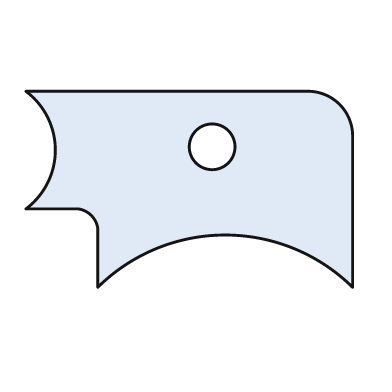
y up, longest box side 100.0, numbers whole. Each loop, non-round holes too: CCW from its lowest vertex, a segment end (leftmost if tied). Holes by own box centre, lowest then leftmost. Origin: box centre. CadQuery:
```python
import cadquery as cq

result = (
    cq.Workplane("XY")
    .moveTo(-28.0, -30.0)
    .threePointArc((11.0, -14.0), (50.0, -30.0))
    .lineTo(50.0, 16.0)
    .threePointArc((46.0, 26.0), (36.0, 30.0))
    .lineTo(-50.0, 30.0)
    .threePointArc((-41.0, 12.0), (-50.0, -6.0))
    .lineTo(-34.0, -6.0)
    .threePointArc((-30.0, -8.0), (-28.0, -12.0))
    .close()
    .moveTo(7.0, 13.0)
    .circle(7.0)
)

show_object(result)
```